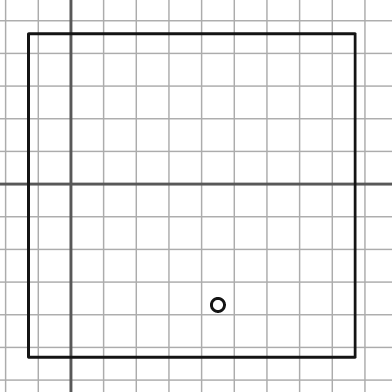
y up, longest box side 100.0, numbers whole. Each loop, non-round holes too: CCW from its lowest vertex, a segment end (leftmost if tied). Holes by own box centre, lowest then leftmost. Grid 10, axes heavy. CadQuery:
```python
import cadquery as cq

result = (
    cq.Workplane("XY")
    .moveTo(-13.0, -53.0)
    .lineTo(87.0, -53.0)
    .lineTo(87.0, 46.0)
    .lineTo(-13.0, 46.0)
    .close()
    .moveTo(45.0, -37.0)
    .circle(2.0)
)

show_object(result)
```